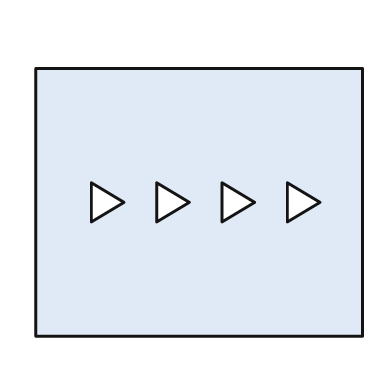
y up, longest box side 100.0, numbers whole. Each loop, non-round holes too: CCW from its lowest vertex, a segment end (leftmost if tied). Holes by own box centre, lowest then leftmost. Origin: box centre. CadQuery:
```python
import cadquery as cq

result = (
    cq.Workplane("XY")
    .moveTo(-50.0, -41.0)
    .lineTo(50.0, -41.0)
    .lineTo(50.0, 41.0)
    .lineTo(-50.0, 41.0)
    .close()
    .moveTo(-33.0, -6.0)
    .lineTo(-23.0, 0.0)
    .lineTo(-33.0, 6.0)
    .close()
    .moveTo(-13.0, -6.0)
    .lineTo(-3.0, 0.0)
    .lineTo(-13.0, 6.0)
    .close()
    .moveTo(7.0, -6.0)
    .lineTo(17.0, 0.0)
    .lineTo(7.0, 6.0)
    .close()
    .moveTo(27.0, -6.0)
    .lineTo(37.0, 0.0)
    .lineTo(27.0, 6.0)
    .close()
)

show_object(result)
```